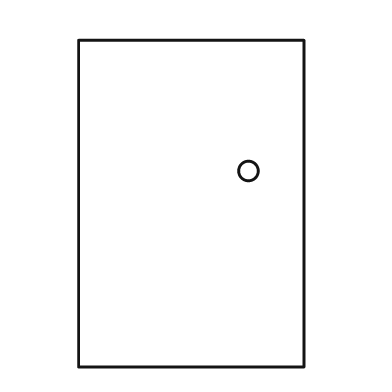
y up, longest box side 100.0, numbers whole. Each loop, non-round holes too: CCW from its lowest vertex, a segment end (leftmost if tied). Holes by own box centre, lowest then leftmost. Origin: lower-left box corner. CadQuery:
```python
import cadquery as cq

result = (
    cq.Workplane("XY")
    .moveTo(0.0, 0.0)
    .lineTo(69.0, 0.0)
    .lineTo(69.0, 100.0)
    .lineTo(0.0, 100.0)
    .close()
    .moveTo(52.0, 60.0)
    .circle(3.0)
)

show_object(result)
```